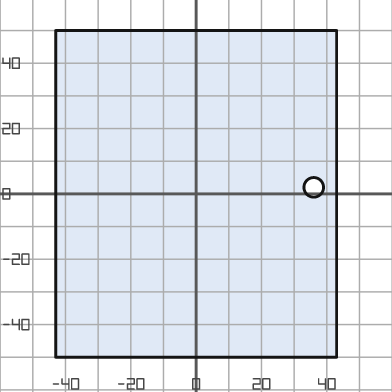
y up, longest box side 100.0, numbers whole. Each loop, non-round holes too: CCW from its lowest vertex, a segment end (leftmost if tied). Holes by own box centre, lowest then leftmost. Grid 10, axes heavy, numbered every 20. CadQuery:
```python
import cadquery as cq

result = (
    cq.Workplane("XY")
    .moveTo(-43.0, -50.0)
    .lineTo(43.0, -50.0)
    .lineTo(43.0, 50.0)
    .lineTo(-43.0, 50.0)
    .close()
    .moveTo(36.0, 2.0)
    .circle(3.0)
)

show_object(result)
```